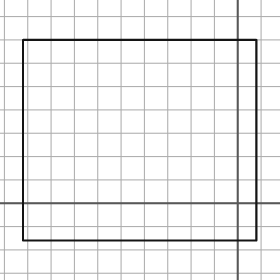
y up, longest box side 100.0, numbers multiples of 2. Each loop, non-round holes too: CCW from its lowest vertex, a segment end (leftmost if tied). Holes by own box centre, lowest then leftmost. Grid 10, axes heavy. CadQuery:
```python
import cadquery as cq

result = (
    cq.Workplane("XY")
    .moveTo(-92.0, -16.0)
    .lineTo(8.0, -16.0)
    .lineTo(8.0, 70.0)
    .lineTo(-92.0, 70.0)
    .close()
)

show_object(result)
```